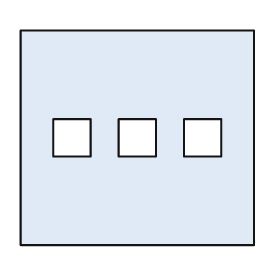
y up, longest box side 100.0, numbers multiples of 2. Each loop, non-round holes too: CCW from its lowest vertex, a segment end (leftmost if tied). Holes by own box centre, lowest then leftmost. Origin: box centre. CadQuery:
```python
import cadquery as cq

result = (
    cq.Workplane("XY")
    .moveTo(-50.0, -46.0)
    .lineTo(50.0, -46.0)
    .lineTo(50.0, 46.0)
    .lineTo(-50.0, 46.0)
    .close()
    .moveTo(-36.0, -8.0)
    .lineTo(-20.0, -8.0)
    .lineTo(-20.0, 8.0)
    .lineTo(-36.0, 8.0)
    .close()
    .moveTo(-8.0, -8.0)
    .lineTo(8.0, -8.0)
    .lineTo(8.0, 8.0)
    .lineTo(-8.0, 8.0)
    .close()
    .moveTo(20.0, -8.0)
    .lineTo(36.0, -8.0)
    .lineTo(36.0, 8.0)
    .lineTo(20.0, 8.0)
    .close()
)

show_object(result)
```